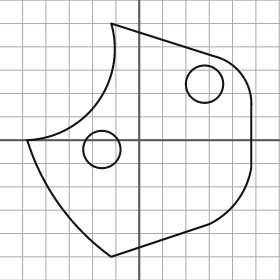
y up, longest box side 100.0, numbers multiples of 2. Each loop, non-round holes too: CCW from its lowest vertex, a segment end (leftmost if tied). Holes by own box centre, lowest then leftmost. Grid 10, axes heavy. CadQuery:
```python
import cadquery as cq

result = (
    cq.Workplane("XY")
    .moveTo(-12.0, -50.0)
    .lineTo(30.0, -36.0)
    .threePointArc((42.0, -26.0), (48.0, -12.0))
    .lineTo(48.0, 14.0)
    .threePointArc((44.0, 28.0), (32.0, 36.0))
    .lineTo(-12.0, 50.0)
    .threePointArc((-18.0, 16.0), (-48.0, 0.0))
    .threePointArc((-34.0, -28.0), (-12.0, -50.0))
    .close()
    .moveTo(-16.0, -4.0)
    .circle(8.0)
    .moveTo(28.0, 24.0)
    .circle(8.0)
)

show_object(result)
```